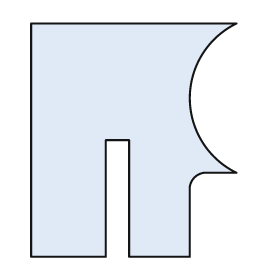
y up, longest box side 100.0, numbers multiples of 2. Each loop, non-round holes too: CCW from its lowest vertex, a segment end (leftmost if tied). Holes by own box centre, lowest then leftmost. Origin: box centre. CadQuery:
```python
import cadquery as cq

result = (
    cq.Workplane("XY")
    .moveTo(-44.0, -50.0)
    .lineTo(-12.0, -50.0)
    .lineTo(-12.0, 0.0)
    .lineTo(-2.0, 0.0)
    .lineTo(-2.0, -50.0)
    .lineTo(24.0, -50.0)
    .lineTo(24.0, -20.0)
    .threePointArc((26.0, -16.0), (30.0, -14.0))
    .lineTo(44.0, -14.0)
    .threePointArc((24.0, 18.0), (44.0, 50.0))
    .lineTo(-44.0, 50.0)
    .close()
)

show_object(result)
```